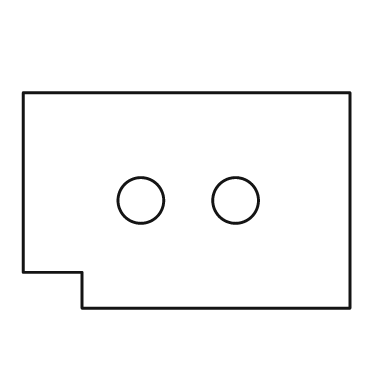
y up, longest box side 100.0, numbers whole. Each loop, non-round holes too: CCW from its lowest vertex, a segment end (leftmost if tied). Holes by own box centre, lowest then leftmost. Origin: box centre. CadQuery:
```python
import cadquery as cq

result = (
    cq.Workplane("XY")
    .moveTo(-32.0, -33.0)
    .lineTo(50.0, -33.0)
    .lineTo(50.0, 33.0)
    .lineTo(-50.0, 33.0)
    .lineTo(-50.0, -22.0)
    .lineTo(-32.0, -22.0)
    .close()
    .moveTo(-14.0, 0.0)
    .circle(7.0)
    .moveTo(15.0, 0.0)
    .circle(7.0)
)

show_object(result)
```